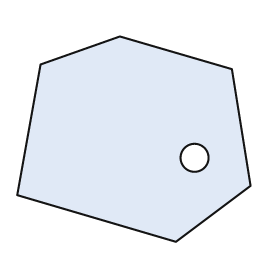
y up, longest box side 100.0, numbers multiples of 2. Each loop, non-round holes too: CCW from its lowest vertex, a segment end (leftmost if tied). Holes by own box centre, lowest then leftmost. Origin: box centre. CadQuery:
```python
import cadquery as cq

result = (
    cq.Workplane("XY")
    .moveTo(18.0, -44.0)
    .lineTo(50.0, -20.0)
    .lineTo(42.0, 30.0)
    .lineTo(-6.0, 44.0)
    .lineTo(-40.0, 32.0)
    .lineTo(-50.0, -24.0)
    .close()
    .moveTo(26.0, -8.0)
    .circle(6.0)
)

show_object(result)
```